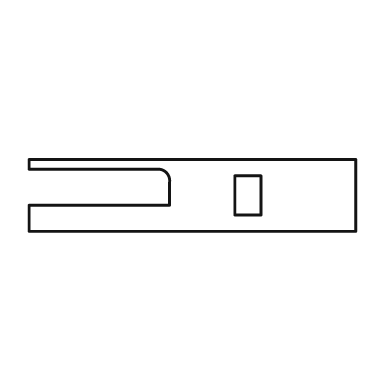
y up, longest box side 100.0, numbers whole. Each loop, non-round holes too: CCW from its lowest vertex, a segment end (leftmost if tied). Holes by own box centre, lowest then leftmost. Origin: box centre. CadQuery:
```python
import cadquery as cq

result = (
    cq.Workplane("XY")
    .moveTo(-50.0, -11.0)
    .lineTo(50.0, -11.0)
    .lineTo(50.0, 11.0)
    .lineTo(-50.0, 11.0)
    .lineTo(-50.0, 8.0)
    .lineTo(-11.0, 8.0)
    .threePointArc((-8.0, 7.0), (-7.0, 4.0))
    .lineTo(-7.0, -3.0)
    .lineTo(-50.0, -3.0)
    .close()
    .moveTo(13.0, -6.0)
    .lineTo(21.0, -6.0)
    .lineTo(21.0, 6.0)
    .lineTo(13.0, 6.0)
    .close()
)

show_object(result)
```